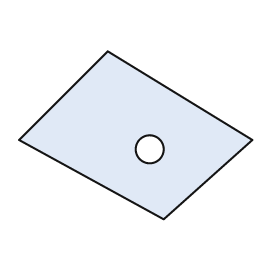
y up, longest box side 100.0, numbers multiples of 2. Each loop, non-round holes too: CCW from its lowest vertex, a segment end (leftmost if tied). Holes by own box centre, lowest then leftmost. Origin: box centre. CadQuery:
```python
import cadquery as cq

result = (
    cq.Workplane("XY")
    .moveTo(12.0, -36.0)
    .lineTo(50.0, -2.0)
    .lineTo(-12.0, 36.0)
    .lineTo(-50.0, -2.0)
    .close()
    .moveTo(6.0, -6.0)
    .circle(6.0)
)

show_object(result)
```